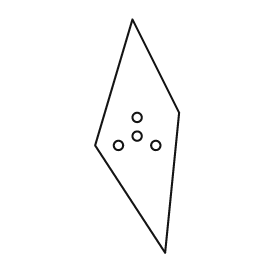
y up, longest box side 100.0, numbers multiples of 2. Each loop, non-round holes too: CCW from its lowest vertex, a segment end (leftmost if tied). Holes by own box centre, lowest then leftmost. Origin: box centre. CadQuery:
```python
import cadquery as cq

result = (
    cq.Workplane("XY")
    .moveTo(12.0, -50.0)
    .lineTo(18.0, 10.0)
    .lineTo(-2.0, 50.0)
    .lineTo(-18.0, -4.0)
    .close()
    .moveTo(-8.0, -4.0)
    .circle(2.0)
    .moveTo(8.0, -4.0)
    .circle(2.0)
    .moveTo(0.0, 0.0)
    .circle(2.0)
    .moveTo(0.0, 8.0)
    .circle(2.0)
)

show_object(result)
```